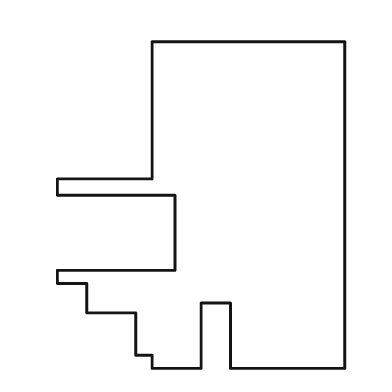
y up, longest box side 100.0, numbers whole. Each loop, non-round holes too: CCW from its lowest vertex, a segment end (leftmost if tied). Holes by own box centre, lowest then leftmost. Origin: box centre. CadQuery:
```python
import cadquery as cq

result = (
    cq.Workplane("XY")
    .moveTo(-15.0, -50.0)
    .lineTo(0.0, -50.0)
    .lineTo(0.0, -30.0)
    .lineTo(9.0, -30.0)
    .lineTo(9.0, -50.0)
    .lineTo(44.0, -50.0)
    .lineTo(44.0, 50.0)
    .lineTo(-15.0, 50.0)
    .lineTo(-15.0, 8.0)
    .lineTo(-44.0, 8.0)
    .lineTo(-44.0, 3.0)
    .lineTo(-8.0, 3.0)
    .lineTo(-8.0, -20.0)
    .lineTo(-44.0, -20.0)
    .lineTo(-44.0, -24.0)
    .lineTo(-35.0, -24.0)
    .lineTo(-35.0, -33.0)
    .lineTo(-20.0, -33.0)
    .lineTo(-20.0, -46.0)
    .lineTo(-15.0, -46.0)
    .close()
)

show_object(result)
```